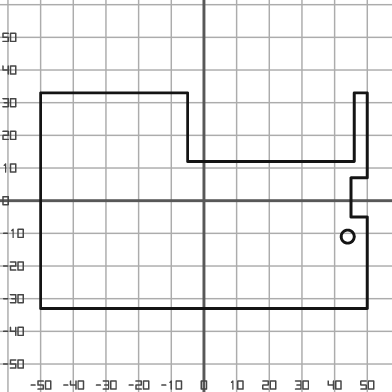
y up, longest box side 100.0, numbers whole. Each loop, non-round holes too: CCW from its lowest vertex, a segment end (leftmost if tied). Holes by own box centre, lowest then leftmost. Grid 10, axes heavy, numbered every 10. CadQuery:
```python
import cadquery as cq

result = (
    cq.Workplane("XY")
    .moveTo(-50.0, -33.0)
    .lineTo(50.0, -33.0)
    .lineTo(50.0, -5.0)
    .lineTo(45.0, -5.0)
    .lineTo(45.0, 7.0)
    .lineTo(50.0, 7.0)
    .lineTo(50.0, 33.0)
    .lineTo(46.0, 33.0)
    .lineTo(46.0, 12.0)
    .lineTo(-5.0, 12.0)
    .lineTo(-5.0, 33.0)
    .lineTo(-50.0, 33.0)
    .close()
    .moveTo(44.0, -11.0)
    .circle(2.0)
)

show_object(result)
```